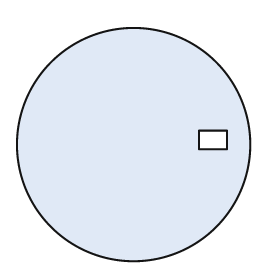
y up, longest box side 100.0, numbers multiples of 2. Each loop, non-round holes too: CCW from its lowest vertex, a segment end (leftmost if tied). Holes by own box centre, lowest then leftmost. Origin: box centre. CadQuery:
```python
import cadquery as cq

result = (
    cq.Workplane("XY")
    .moveTo(0.0, 0.0)
    .circle(50.0)
    .moveTo(28.0, -2.0)
    .lineTo(40.0, -2.0)
    .lineTo(40.0, 6.0)
    .lineTo(28.0, 6.0)
    .close()
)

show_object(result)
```